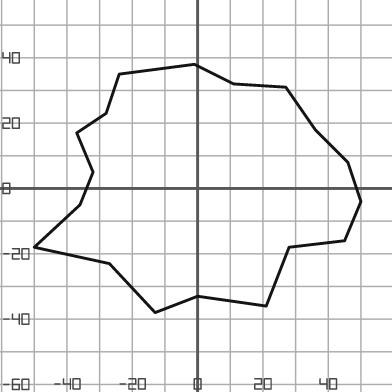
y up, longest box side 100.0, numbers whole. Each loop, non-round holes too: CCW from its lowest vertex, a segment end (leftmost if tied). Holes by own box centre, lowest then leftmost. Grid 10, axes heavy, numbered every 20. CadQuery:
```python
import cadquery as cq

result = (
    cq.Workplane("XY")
    .moveTo(-13.0, -38.0)
    .lineTo(0.0, -33.0)
    .lineTo(21.0, -36.0)
    .lineTo(28.0, -18.0)
    .lineTo(45.0, -16.0)
    .lineTo(50.0, -4.0)
    .lineTo(46.0, 8.0)
    .lineTo(36.0, 18.0)
    .lineTo(27.0, 31.0)
    .lineTo(11.0, 32.0)
    .lineTo(-1.0, 38.0)
    .lineTo(-24.0, 35.0)
    .lineTo(-28.0, 23.0)
    .lineTo(-37.0, 17.0)
    .lineTo(-32.0, 5.0)
    .lineTo(-36.0, -5.0)
    .lineTo(-50.0, -18.0)
    .lineTo(-27.0, -23.0)
    .close()
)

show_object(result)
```